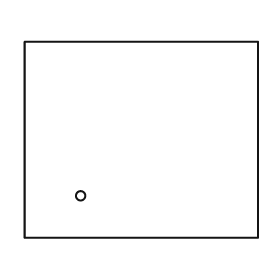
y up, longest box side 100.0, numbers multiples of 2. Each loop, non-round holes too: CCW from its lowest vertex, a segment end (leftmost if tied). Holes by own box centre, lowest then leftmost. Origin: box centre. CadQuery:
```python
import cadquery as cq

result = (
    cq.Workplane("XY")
    .moveTo(-50.0, -42.0)
    .lineTo(50.0, -42.0)
    .lineTo(50.0, 42.0)
    .lineTo(-50.0, 42.0)
    .close()
    .moveTo(-26.0, -24.0)
    .circle(2.0)
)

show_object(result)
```